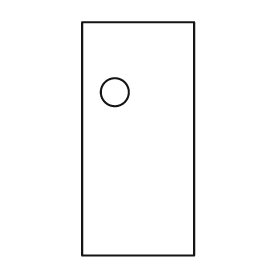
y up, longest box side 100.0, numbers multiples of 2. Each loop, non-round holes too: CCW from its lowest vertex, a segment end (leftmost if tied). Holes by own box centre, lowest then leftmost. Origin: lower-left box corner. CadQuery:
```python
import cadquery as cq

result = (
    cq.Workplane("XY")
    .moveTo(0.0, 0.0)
    .lineTo(48.0, 0.0)
    .lineTo(48.0, 100.0)
    .lineTo(0.0, 100.0)
    .close()
    .moveTo(14.0, 70.0)
    .circle(6.0)
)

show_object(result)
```